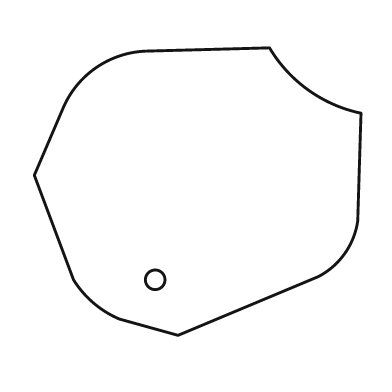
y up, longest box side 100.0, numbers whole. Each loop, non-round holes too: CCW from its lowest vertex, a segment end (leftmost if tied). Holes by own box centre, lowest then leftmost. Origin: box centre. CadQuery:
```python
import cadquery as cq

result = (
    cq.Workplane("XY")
    .moveTo(-6.0, -44.0)
    .lineTo(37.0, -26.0)
    .threePointArc((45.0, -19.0), (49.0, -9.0))
    .lineTo(50.0, 24.0)
    .threePointArc((34.0, 31.0), (22.0, 44.0))
    .lineTo(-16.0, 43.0)
    .threePointArc((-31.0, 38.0), (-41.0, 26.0))
    .lineTo(-50.0, 5.0)
    .lineTo(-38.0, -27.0)
    .threePointArc((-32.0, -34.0), (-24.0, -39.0))
    .close()
    .moveTo(-13.0, -27.0)
    .circle(3.0)
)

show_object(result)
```